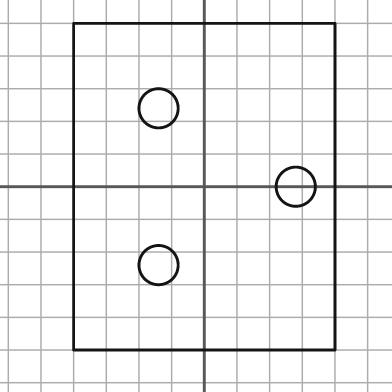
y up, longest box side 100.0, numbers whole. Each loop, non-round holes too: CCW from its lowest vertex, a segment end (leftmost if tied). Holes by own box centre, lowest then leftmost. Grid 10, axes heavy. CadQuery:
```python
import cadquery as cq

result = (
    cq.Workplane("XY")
    .moveTo(-40.0, -50.0)
    .lineTo(40.0, -50.0)
    .lineTo(40.0, 50.0)
    .lineTo(-40.0, 50.0)
    .close()
    .moveTo(-14.0, -24.0)
    .circle(6.0)
    .moveTo(28.0, 0.0)
    .circle(6.0)
    .moveTo(-14.0, 24.0)
    .circle(6.0)
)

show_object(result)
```